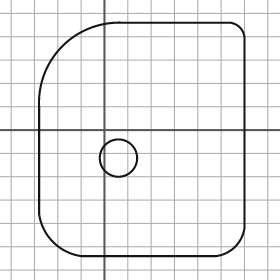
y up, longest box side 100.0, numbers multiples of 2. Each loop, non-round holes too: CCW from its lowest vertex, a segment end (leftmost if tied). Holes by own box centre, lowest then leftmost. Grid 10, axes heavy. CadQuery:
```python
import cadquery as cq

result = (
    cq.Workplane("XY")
    .moveTo(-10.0, -54.0)
    .lineTo(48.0, -54.0)
    .threePointArc((56.0, -50.0), (60.0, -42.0))
    .lineTo(60.0, 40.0)
    .threePointArc((58.0, 44.0), (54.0, 46.0))
    .lineTo(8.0, 46.0)
    .threePointArc((-18.0, 36.0), (-28.0, 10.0))
    .lineTo(-28.0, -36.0)
    .threePointArc((-22.0, -48.0), (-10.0, -54.0))
    .close()
    .moveTo(6.0, -12.0)
    .circle(8.0)
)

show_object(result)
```